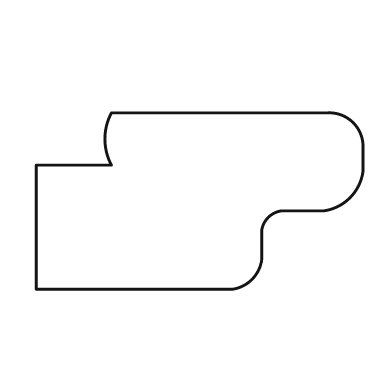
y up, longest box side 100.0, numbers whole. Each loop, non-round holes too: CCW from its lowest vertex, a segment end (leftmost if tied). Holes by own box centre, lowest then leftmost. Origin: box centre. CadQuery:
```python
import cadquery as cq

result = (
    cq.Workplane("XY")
    .moveTo(-50.0, -27.0)
    .lineTo(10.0, -27.0)
    .threePointArc((16.0, -24.0), (19.0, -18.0))
    .lineTo(19.0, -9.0)
    .threePointArc((21.0, -5.0), (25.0, -3.0))
    .lineTo(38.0, -3.0)
    .threePointArc((46.0, 1.0), (50.0, 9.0))
    .lineTo(50.0, 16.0)
    .threePointArc((47.0, 24.0), (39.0, 27.0))
    .lineTo(-27.0, 27.0)
    .threePointArc((-29.0, 19.0), (-27.0, 11.0))
    .lineTo(-50.0, 11.0)
    .close()
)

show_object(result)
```